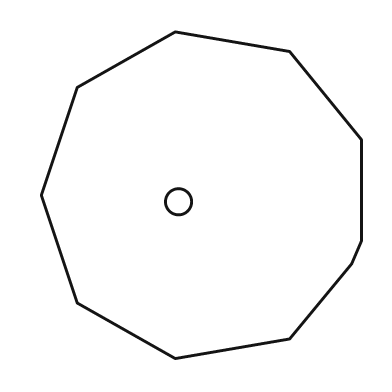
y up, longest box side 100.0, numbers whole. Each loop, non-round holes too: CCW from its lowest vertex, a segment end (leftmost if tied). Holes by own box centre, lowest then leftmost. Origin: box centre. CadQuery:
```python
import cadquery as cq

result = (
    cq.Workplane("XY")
    .moveTo(-8.0, -50.0)
    .lineTo(27.0, -44.0)
    .lineTo(46.0, -21.0)
    .lineTo(49.0, -14.0)
    .lineTo(49.0, 17.0)
    .lineTo(27.0, 44.0)
    .lineTo(-8.0, 50.0)
    .lineTo(-38.0, 33.0)
    .lineTo(-49.0, 0.0)
    .lineTo(-38.0, -33.0)
    .close()
    .moveTo(-7.0, -2.0)
    .circle(4.0)
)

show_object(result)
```